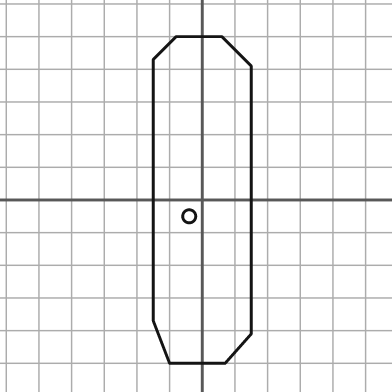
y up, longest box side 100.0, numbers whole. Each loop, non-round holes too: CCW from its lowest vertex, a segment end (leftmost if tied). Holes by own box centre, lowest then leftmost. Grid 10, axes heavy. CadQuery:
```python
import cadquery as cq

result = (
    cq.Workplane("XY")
    .moveTo(-10.0, -50.0)
    .lineTo(7.0, -50.0)
    .lineTo(15.0, -41.0)
    .lineTo(15.0, 41.0)
    .lineTo(6.0, 50.0)
    .lineTo(-8.0, 50.0)
    .lineTo(-15.0, 43.0)
    .lineTo(-15.0, -37.0)
    .close()
    .moveTo(-4.0, -5.0)
    .circle(2.0)
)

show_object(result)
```